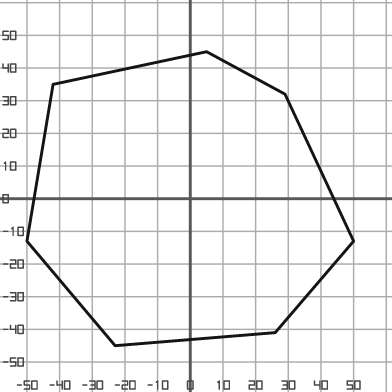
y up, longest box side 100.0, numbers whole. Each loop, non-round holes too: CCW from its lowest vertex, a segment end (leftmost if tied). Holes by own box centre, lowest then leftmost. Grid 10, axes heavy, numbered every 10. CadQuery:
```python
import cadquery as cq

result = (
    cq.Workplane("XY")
    .moveTo(-23.0, -45.0)
    .lineTo(26.0, -41.0)
    .lineTo(50.0, -13.0)
    .lineTo(29.0, 32.0)
    .lineTo(5.0, 45.0)
    .lineTo(-42.0, 35.0)
    .lineTo(-50.0, -13.0)
    .close()
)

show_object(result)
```